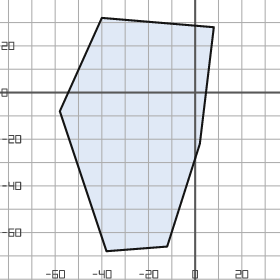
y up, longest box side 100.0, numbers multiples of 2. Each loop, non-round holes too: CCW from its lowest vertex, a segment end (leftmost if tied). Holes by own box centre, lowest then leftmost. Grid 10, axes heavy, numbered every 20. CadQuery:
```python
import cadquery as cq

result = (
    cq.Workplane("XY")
    .moveTo(-38.0, -68.0)
    .lineTo(-12.0, -66.0)
    .lineTo(2.0, -22.0)
    .lineTo(8.0, 28.0)
    .lineTo(-40.0, 32.0)
    .lineTo(-58.0, -8.0)
    .close()
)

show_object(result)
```